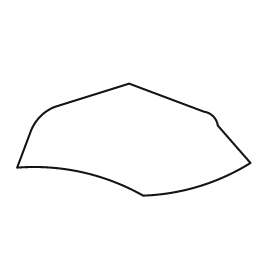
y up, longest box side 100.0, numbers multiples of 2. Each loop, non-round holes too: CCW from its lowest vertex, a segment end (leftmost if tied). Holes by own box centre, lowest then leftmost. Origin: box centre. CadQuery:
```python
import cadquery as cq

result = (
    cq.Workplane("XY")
    .moveTo(4.0, -24.0)
    .threePointArc((28.0, -20.0), (50.0, -10.0))
    .lineTo(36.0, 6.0)
    .threePointArc((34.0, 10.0), (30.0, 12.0))
    .lineTo(-2.0, 24.0)
    .lineTo(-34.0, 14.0)
    .threePointArc((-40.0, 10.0), (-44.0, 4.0))
    .lineTo(-50.0, -12.0)
    .threePointArc((-22.0, -14.0), (4.0, -24.0))
    .close()
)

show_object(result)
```